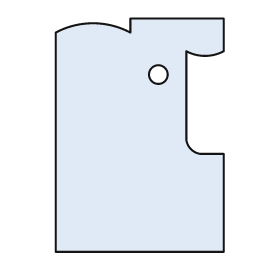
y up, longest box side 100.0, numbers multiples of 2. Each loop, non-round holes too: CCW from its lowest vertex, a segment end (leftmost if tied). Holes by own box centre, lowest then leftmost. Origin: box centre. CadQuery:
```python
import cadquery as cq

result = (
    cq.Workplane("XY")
    .moveTo(-36.0, -50.0)
    .lineTo(36.0, -50.0)
    .lineTo(36.0, -8.0)
    .lineTo(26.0, -8.0)
    .threePointArc((22.0, -6.0), (20.0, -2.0))
    .lineTo(20.0, 36.0)
    .threePointArc((28.0, 34.0), (36.0, 36.0))
    .lineTo(36.0, 50.0)
    .lineTo(-4.0, 50.0)
    .lineTo(-4.0, 44.0)
    .threePointArc((-20.0, 48.0), (-36.0, 44.0))
    .close()
    .moveTo(8.0, 26.0)
    .circle(4.0)
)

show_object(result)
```